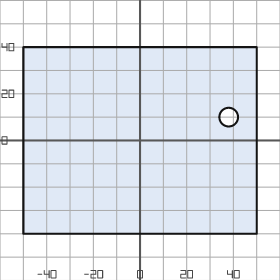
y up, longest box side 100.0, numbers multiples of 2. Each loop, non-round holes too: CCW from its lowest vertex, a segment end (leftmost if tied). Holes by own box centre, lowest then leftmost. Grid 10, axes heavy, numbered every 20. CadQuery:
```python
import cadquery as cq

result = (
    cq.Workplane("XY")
    .moveTo(-50.0, -40.0)
    .lineTo(50.0, -40.0)
    .lineTo(50.0, 40.0)
    .lineTo(-50.0, 40.0)
    .close()
    .moveTo(38.0, 10.0)
    .circle(4.0)
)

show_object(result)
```